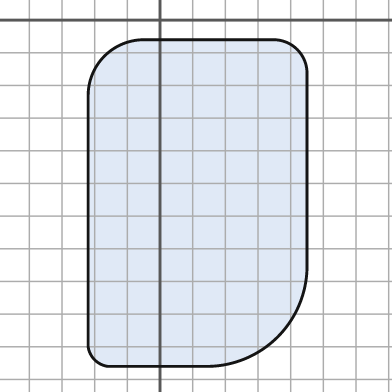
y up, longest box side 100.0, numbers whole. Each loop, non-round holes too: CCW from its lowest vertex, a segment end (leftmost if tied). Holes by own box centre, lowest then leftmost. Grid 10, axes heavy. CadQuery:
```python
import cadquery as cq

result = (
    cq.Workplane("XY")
    .moveTo(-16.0, -106.0)
    .lineTo(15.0, -106.0)
    .threePointArc((36.0, -97.0), (45.0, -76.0))
    .lineTo(45.0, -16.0)
    .threePointArc((42.0, -9.0), (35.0, -6.0))
    .lineTo(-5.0, -6.0)
    .threePointArc((-17.0, -11.0), (-22.0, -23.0))
    .lineTo(-22.0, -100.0)
    .threePointArc((-20.0, -104.0), (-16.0, -106.0))
    .close()
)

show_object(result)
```